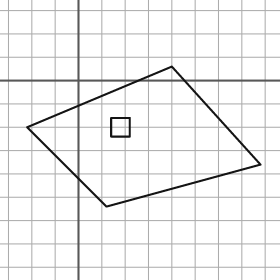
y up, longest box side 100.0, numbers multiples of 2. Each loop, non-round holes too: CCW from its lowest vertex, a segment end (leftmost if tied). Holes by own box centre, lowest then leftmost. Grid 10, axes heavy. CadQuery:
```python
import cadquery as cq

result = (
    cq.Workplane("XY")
    .moveTo(12.0, -54.0)
    .lineTo(78.0, -36.0)
    .lineTo(40.0, 6.0)
    .lineTo(-22.0, -20.0)
    .close()
    .moveTo(14.0, -24.0)
    .lineTo(22.0, -24.0)
    .lineTo(22.0, -16.0)
    .lineTo(14.0, -16.0)
    .close()
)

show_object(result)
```